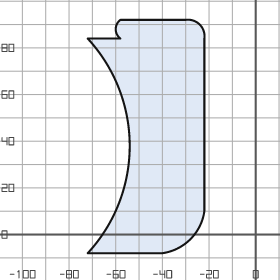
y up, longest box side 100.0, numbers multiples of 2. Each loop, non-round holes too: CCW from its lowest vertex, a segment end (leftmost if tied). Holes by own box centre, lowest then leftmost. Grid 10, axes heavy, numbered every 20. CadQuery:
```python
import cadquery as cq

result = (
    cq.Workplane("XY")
    .moveTo(-72.0, -8.0)
    .lineTo(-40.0, -8.0)
    .threePointArc((-28.0, -2.0), (-22.0, 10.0))
    .lineTo(-22.0, 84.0)
    .threePointArc((-24.0, 90.0), (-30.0, 92.0))
    .lineTo(-58.0, 92.0)
    .threePointArc((-60.0, 88.0), (-58.0, 84.0))
    .lineTo(-72.0, 84.0)
    .threePointArc((-54.0, 38.0), (-72.0, -8.0))
    .close()
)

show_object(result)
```